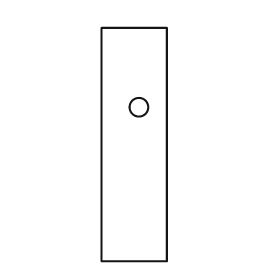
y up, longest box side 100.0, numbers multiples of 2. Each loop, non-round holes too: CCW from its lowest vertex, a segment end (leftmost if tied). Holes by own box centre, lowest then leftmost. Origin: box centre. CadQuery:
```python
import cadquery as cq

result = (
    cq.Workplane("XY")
    .moveTo(-14.0, -50.0)
    .lineTo(14.0, -50.0)
    .lineTo(14.0, 50.0)
    .lineTo(-14.0, 50.0)
    .close()
    .moveTo(2.0, 16.0)
    .circle(4.0)
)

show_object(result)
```